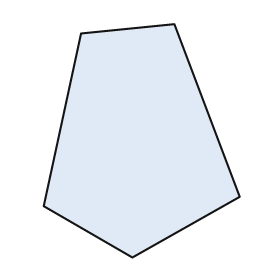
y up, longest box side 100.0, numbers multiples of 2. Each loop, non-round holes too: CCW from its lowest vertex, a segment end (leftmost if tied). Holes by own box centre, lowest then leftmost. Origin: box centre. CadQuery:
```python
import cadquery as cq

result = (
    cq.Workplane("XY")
    .moveTo(-4.0, -50.0)
    .lineTo(42.0, -24.0)
    .lineTo(14.0, 50.0)
    .lineTo(-26.0, 46.0)
    .lineTo(-42.0, -28.0)
    .close()
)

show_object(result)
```